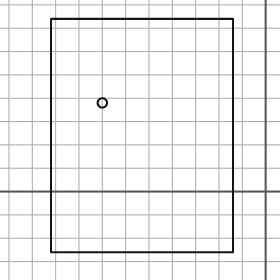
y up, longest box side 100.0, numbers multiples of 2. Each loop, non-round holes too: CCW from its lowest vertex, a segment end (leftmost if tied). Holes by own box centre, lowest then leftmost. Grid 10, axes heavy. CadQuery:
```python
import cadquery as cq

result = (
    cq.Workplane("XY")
    .moveTo(-92.0, -26.0)
    .lineTo(-14.0, -26.0)
    .lineTo(-14.0, 74.0)
    .lineTo(-92.0, 74.0)
    .close()
    .moveTo(-70.0, 38.0)
    .circle(2.0)
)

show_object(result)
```